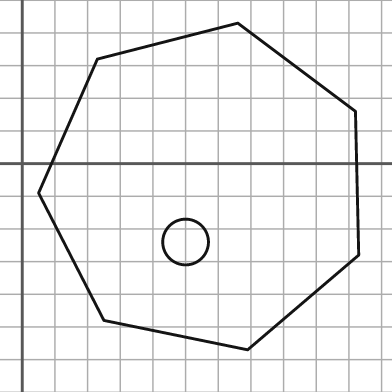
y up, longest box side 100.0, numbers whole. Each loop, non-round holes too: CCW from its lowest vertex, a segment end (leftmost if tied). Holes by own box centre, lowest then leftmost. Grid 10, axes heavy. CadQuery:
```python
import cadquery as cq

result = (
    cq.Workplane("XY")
    .moveTo(69.0, -57.0)
    .lineTo(103.0, -28.0)
    .lineTo(102.0, 16.0)
    .lineTo(66.0, 43.0)
    .lineTo(23.0, 32.0)
    .lineTo(5.0, -9.0)
    .lineTo(25.0, -48.0)
    .close()
    .moveTo(50.0, -24.0)
    .circle(7.0)
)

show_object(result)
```